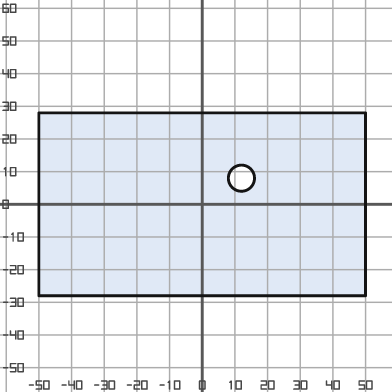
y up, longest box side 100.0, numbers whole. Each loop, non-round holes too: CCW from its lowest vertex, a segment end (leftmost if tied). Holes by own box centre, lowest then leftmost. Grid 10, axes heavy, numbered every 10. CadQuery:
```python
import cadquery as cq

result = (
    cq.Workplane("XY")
    .moveTo(-50.0, -28.0)
    .lineTo(50.0, -28.0)
    .lineTo(50.0, 28.0)
    .lineTo(-50.0, 28.0)
    .close()
    .moveTo(12.0, 8.0)
    .circle(4.0)
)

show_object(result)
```